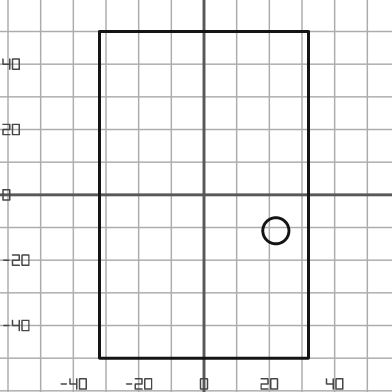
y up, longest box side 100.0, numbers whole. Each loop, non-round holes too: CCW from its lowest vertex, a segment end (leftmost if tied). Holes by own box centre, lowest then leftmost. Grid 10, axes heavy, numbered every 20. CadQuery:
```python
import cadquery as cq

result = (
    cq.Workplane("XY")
    .moveTo(-32.0, -50.0)
    .lineTo(32.0, -50.0)
    .lineTo(32.0, 50.0)
    .lineTo(-32.0, 50.0)
    .close()
    .moveTo(22.0, -11.0)
    .circle(4.0)
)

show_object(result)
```